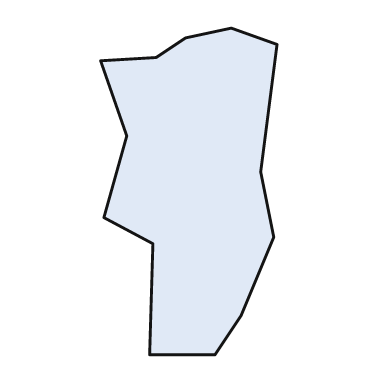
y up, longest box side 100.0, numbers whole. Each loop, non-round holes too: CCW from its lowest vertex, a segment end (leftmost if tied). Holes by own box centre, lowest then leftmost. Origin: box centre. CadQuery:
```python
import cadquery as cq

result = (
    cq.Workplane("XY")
    .moveTo(-12.0, -50.0)
    .lineTo(8.0, -50.0)
    .lineTo(16.0, -38.0)
    .lineTo(26.0, -14.0)
    .lineTo(22.0, 6.0)
    .lineTo(27.0, 45.0)
    .lineTo(13.0, 50.0)
    .lineTo(-1.0, 47.0)
    .lineTo(-10.0, 41.0)
    .lineTo(-27.0, 40.0)
    .lineTo(-19.0, 17.0)
    .lineTo(-26.0, -8.0)
    .lineTo(-11.0, -16.0)
    .close()
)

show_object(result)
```